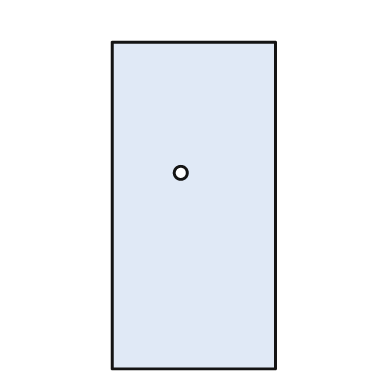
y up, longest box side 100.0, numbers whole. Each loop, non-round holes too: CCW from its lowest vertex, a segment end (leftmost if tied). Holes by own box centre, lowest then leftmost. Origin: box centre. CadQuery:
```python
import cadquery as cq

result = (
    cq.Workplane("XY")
    .moveTo(-25.0, -50.0)
    .lineTo(25.0, -50.0)
    .lineTo(25.0, 50.0)
    .lineTo(-25.0, 50.0)
    .close()
    .moveTo(-4.0, 10.0)
    .circle(2.0)
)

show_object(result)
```